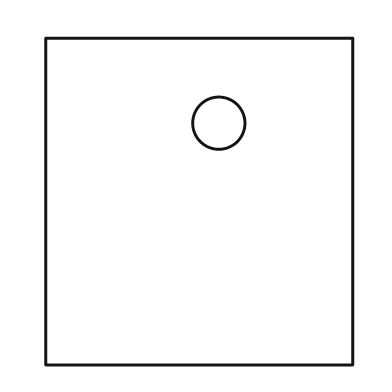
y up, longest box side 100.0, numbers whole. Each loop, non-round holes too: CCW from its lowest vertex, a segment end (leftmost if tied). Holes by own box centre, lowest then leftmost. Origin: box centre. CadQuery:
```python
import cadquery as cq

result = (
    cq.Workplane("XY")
    .moveTo(-47.0, -50.0)
    .lineTo(47.0, -50.0)
    .lineTo(47.0, 50.0)
    .lineTo(-47.0, 50.0)
    .close()
    .moveTo(6.0, 24.0)
    .circle(8.0)
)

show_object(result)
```